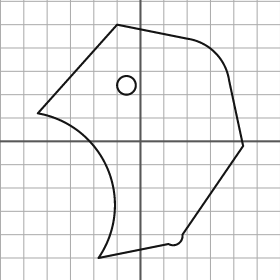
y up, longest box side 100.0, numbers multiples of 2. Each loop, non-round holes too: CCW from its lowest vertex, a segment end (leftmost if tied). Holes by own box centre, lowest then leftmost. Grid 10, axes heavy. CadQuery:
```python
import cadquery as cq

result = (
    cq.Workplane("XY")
    .moveTo(-18.0, -50.0)
    .lineTo(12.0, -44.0)
    .threePointArc((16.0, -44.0), (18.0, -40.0))
    .lineTo(44.0, -2.0)
    .lineTo(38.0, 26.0)
    .threePointArc((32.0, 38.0), (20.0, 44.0))
    .lineTo(-10.0, 50.0)
    .lineTo(-44.0, 12.0)
    .threePointArc((-14.0, -12.0), (-18.0, -50.0))
    .close()
    .moveTo(-6.0, 24.0)
    .circle(4.0)
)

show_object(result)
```